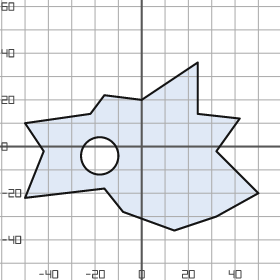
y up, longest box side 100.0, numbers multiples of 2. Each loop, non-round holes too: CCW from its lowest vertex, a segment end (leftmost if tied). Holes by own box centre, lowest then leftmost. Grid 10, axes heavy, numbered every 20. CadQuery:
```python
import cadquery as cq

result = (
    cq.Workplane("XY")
    .moveTo(14.0, -36.0)
    .lineTo(32.0, -30.0)
    .lineTo(50.0, -20.0)
    .lineTo(32.0, -2.0)
    .lineTo(42.0, 12.0)
    .lineTo(24.0, 14.0)
    .lineTo(24.0, 36.0)
    .lineTo(0.0, 20.0)
    .lineTo(-16.0, 22.0)
    .lineTo(-22.0, 14.0)
    .lineTo(-50.0, 10.0)
    .lineTo(-42.0, -2.0)
    .lineTo(-50.0, -22.0)
    .lineTo(-16.0, -18.0)
    .lineTo(-8.0, -28.0)
    .close()
    .moveTo(-18.0, -4.0)
    .circle(8.0)
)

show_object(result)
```